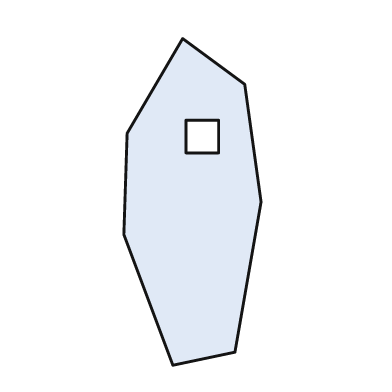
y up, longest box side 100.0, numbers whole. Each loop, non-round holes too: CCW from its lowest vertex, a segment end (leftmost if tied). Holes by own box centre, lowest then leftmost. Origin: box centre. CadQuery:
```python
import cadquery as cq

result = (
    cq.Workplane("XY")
    .moveTo(-6.0, -50.0)
    .lineTo(13.0, -46.0)
    .lineTo(21.0, 0.0)
    .lineTo(16.0, 36.0)
    .lineTo(-3.0, 50.0)
    .lineTo(-20.0, 21.0)
    .lineTo(-21.0, -10.0)
    .close()
    .moveTo(-2.0, 15.0)
    .lineTo(8.0, 15.0)
    .lineTo(8.0, 25.0)
    .lineTo(-2.0, 25.0)
    .close()
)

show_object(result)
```